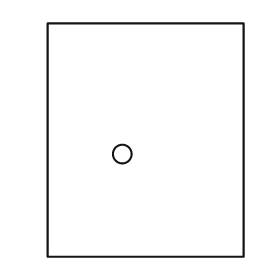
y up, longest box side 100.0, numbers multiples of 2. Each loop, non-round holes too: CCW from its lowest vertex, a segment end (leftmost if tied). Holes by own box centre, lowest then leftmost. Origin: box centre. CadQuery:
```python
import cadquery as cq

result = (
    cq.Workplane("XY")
    .moveTo(-42.0, -50.0)
    .lineTo(42.0, -50.0)
    .lineTo(42.0, 50.0)
    .lineTo(-42.0, 50.0)
    .close()
    .moveTo(-10.0, -6.0)
    .circle(4.0)
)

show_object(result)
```